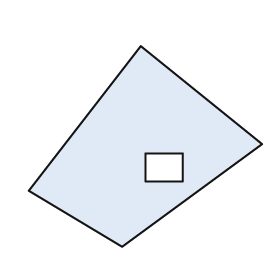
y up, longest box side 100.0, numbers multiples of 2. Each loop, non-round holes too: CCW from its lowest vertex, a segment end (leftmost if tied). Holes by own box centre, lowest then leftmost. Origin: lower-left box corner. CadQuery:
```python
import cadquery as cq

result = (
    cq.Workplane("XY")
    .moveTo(40.0, 0.0)
    .lineTo(100.0, 44.0)
    .lineTo(48.0, 86.0)
    .lineTo(0.0, 24.0)
    .close()
    .moveTo(50.0, 28.0)
    .lineTo(66.0, 28.0)
    .lineTo(66.0, 40.0)
    .lineTo(50.0, 40.0)
    .close()
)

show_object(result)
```